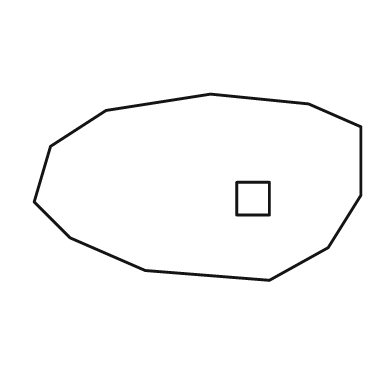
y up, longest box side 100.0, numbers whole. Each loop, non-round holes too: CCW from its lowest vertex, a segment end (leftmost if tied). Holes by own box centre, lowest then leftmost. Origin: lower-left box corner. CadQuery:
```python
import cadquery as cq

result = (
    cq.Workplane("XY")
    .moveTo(72.0, 0.0)
    .lineTo(90.0, 10.0)
    .lineTo(100.0, 26.0)
    .lineTo(100.0, 47.0)
    .lineTo(84.0, 54.0)
    .lineTo(54.0, 57.0)
    .lineTo(22.0, 52.0)
    .lineTo(5.0, 41.0)
    .lineTo(0.0, 24.0)
    .lineTo(11.0, 13.0)
    .lineTo(34.0, 3.0)
    .close()
    .moveTo(62.0, 20.0)
    .lineTo(72.0, 20.0)
    .lineTo(72.0, 30.0)
    .lineTo(62.0, 30.0)
    .close()
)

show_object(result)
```